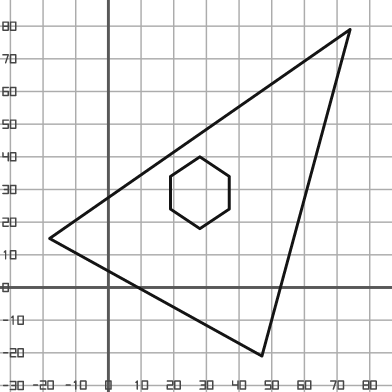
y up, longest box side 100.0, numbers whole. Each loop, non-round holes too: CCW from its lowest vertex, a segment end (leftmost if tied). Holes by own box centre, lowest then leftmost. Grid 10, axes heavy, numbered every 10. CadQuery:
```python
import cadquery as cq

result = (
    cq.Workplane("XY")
    .moveTo(47.0, -21.0)
    .lineTo(74.0, 79.0)
    .lineTo(-18.0, 15.0)
    .close()
    .moveTo(28.0, 18.0)
    .lineTo(37.0, 24.0)
    .lineTo(37.0, 34.0)
    .lineTo(28.0, 40.0)
    .lineTo(19.0, 34.0)
    .lineTo(19.0, 24.0)
    .close()
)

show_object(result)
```